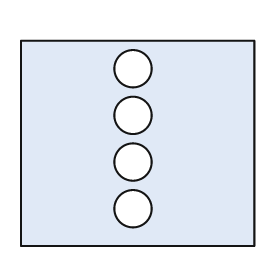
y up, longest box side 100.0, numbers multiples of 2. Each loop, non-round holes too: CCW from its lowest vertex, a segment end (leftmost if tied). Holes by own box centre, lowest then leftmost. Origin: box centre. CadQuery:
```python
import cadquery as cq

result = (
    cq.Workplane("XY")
    .moveTo(-50.0, -44.0)
    .lineTo(50.0, -44.0)
    .lineTo(50.0, 44.0)
    .lineTo(-50.0, 44.0)
    .close()
    .moveTo(-2.0, -28.0)
    .circle(8.0)
    .moveTo(-2.0, -8.0)
    .circle(8.0)
    .moveTo(-2.0, 12.0)
    .circle(8.0)
    .moveTo(-2.0, 32.0)
    .circle(8.0)
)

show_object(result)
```